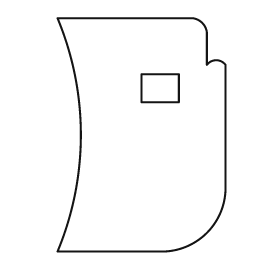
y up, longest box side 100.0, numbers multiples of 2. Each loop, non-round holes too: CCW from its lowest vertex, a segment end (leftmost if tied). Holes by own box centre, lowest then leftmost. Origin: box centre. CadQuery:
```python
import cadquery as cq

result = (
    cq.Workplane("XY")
    .moveTo(-36.0, -50.0)
    .lineTo(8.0, -50.0)
    .threePointArc((28.0, -42.0), (36.0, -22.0))
    .lineTo(36.0, 30.0)
    .threePointArc((32.0, 32.0), (28.0, 30.0))
    .lineTo(28.0, 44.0)
    .threePointArc((26.0, 48.0), (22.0, 50.0))
    .lineTo(-36.0, 50.0)
    .threePointArc((-26.0, 0.0), (-36.0, -50.0))
    .close()
    .moveTo(0.0, 14.0)
    .lineTo(16.0, 14.0)
    .lineTo(16.0, 26.0)
    .lineTo(0.0, 26.0)
    .close()
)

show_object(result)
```